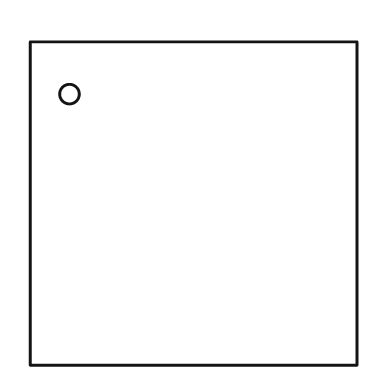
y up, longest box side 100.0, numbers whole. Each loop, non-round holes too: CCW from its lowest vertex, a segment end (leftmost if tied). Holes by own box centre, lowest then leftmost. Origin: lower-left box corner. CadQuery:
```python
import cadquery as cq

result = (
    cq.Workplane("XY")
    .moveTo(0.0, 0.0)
    .lineTo(100.0, 0.0)
    .lineTo(100.0, 99.0)
    .lineTo(0.0, 99.0)
    .close()
    .moveTo(12.0, 83.0)
    .circle(3.0)
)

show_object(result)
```